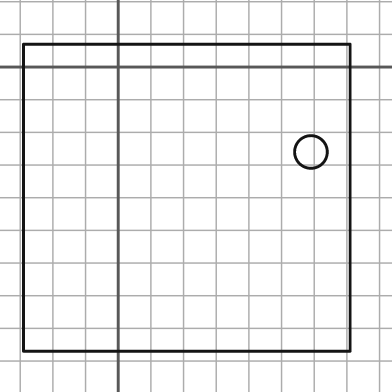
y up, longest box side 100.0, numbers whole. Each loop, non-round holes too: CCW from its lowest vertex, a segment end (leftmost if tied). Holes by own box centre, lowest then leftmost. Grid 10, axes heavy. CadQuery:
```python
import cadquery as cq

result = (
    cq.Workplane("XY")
    .moveTo(-29.0, -87.0)
    .lineTo(71.0, -87.0)
    .lineTo(71.0, 7.0)
    .lineTo(-29.0, 7.0)
    .close()
    .moveTo(59.0, -26.0)
    .circle(5.0)
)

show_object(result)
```